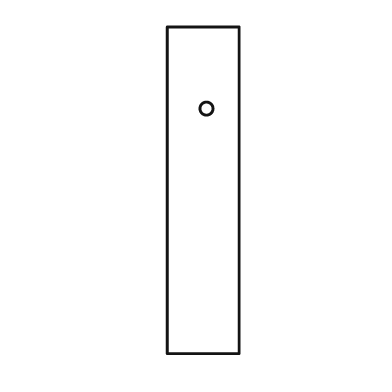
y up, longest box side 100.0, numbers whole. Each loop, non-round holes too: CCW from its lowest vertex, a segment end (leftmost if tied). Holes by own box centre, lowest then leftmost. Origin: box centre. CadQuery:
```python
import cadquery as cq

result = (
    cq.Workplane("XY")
    .moveTo(-11.0, -50.0)
    .lineTo(11.0, -50.0)
    .lineTo(11.0, 50.0)
    .lineTo(-11.0, 50.0)
    .close()
    .moveTo(1.0, 25.0)
    .circle(2.0)
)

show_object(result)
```